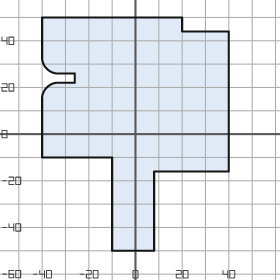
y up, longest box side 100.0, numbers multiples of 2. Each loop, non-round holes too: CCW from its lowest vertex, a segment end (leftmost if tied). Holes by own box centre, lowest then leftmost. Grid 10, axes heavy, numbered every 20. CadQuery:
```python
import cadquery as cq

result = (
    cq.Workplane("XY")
    .moveTo(-10.0, -50.0)
    .lineTo(8.0, -50.0)
    .lineTo(8.0, -16.0)
    .lineTo(40.0, -16.0)
    .lineTo(40.0, 44.0)
    .lineTo(20.0, 44.0)
    .lineTo(20.0, 50.0)
    .lineTo(-40.0, 50.0)
    .lineTo(-40.0, 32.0)
    .threePointArc((-38.0, 28.0), (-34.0, 26.0))
    .lineTo(-26.0, 26.0)
    .lineTo(-26.0, 22.0)
    .lineTo(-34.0, 22.0)
    .threePointArc((-38.0, 20.0), (-40.0, 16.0))
    .lineTo(-40.0, -10.0)
    .lineTo(-10.0, -10.0)
    .close()
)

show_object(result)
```